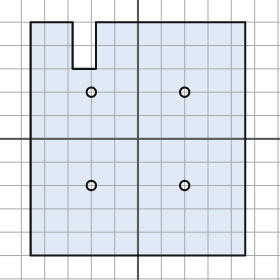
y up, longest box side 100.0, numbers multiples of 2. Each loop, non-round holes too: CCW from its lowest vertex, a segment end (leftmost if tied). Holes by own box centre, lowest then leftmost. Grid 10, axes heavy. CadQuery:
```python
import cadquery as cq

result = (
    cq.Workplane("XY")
    .moveTo(-46.0, -50.0)
    .lineTo(46.0, -50.0)
    .lineTo(46.0, 50.0)
    .lineTo(-18.0, 50.0)
    .lineTo(-18.0, 30.0)
    .lineTo(-28.0, 30.0)
    .lineTo(-28.0, 50.0)
    .lineTo(-46.0, 50.0)
    .close()
    .moveTo(-20.0, -20.0)
    .circle(2.0)
    .moveTo(20.0, -20.0)
    .circle(2.0)
    .moveTo(-20.0, 20.0)
    .circle(2.0)
    .moveTo(20.0, 20.0)
    .circle(2.0)
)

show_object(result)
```